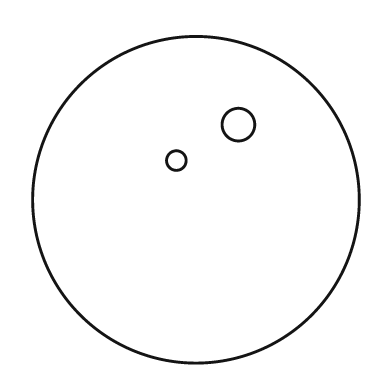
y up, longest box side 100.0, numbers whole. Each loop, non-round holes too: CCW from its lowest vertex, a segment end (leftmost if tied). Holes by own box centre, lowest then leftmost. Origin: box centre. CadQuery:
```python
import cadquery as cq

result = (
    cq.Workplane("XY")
    .moveTo(0.0, 0.0)
    .circle(50.0)
    .moveTo(-6.0, 12.0)
    .circle(3.0)
    .moveTo(13.0, 23.0)
    .circle(5.0)
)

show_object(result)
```